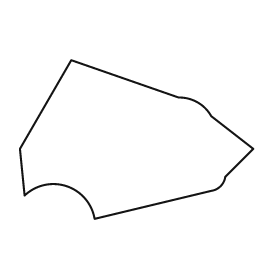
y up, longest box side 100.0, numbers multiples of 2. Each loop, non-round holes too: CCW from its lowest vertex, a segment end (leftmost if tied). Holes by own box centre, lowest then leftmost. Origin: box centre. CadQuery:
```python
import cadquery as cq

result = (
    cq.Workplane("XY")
    .moveTo(-18.0, -34.0)
    .lineTo(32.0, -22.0)
    .threePointArc((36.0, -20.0), (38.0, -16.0))
    .lineTo(50.0, -4.0)
    .lineTo(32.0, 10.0)
    .threePointArc((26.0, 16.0), (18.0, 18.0))
    .lineTo(-28.0, 34.0)
    .lineTo(-50.0, -4.0)
    .lineTo(-48.0, -24.0)
    .threePointArc((-30.0, -20.0), (-18.0, -34.0))
    .close()
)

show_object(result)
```